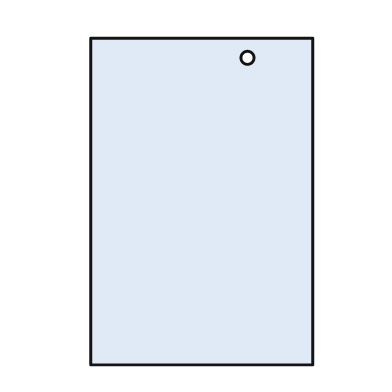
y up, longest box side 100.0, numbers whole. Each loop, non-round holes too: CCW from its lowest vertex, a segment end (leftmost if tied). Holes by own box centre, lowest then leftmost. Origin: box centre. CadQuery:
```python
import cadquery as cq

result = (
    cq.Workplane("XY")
    .moveTo(-34.0, -50.0)
    .lineTo(34.0, -50.0)
    .lineTo(34.0, 50.0)
    .lineTo(-34.0, 50.0)
    .close()
    .moveTo(14.0, 44.0)
    .circle(2.0)
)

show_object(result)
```